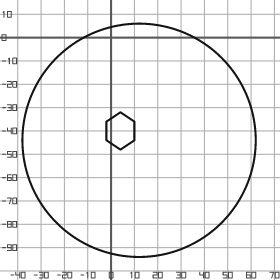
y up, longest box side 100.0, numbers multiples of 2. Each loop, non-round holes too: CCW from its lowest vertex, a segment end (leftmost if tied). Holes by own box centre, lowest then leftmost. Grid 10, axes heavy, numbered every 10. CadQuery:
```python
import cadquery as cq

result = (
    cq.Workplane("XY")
    .moveTo(12.0, -44.0)
    .circle(50.0)
    .moveTo(4.0, -48.0)
    .lineTo(10.0, -44.0)
    .lineTo(10.0, -36.0)
    .lineTo(4.0, -32.0)
    .lineTo(-2.0, -36.0)
    .lineTo(-2.0, -44.0)
    .close()
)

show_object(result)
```